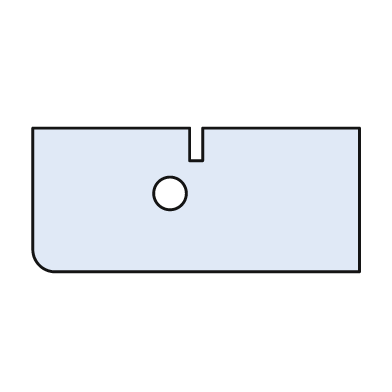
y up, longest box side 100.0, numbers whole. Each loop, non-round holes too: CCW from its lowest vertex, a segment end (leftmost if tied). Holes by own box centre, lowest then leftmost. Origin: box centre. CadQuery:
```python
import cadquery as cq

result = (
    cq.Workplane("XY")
    .moveTo(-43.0, -22.0)
    .lineTo(50.0, -22.0)
    .lineTo(50.0, 22.0)
    .lineTo(2.0, 22.0)
    .lineTo(2.0, 12.0)
    .lineTo(-2.0, 12.0)
    .lineTo(-2.0, 22.0)
    .lineTo(-50.0, 22.0)
    .lineTo(-50.0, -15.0)
    .threePointArc((-48.0, -20.0), (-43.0, -22.0))
    .close()
    .moveTo(-8.0, 2.0)
    .circle(5.0)
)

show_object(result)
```